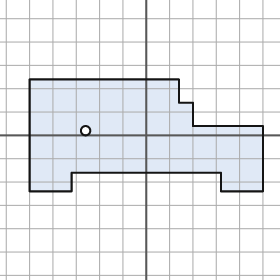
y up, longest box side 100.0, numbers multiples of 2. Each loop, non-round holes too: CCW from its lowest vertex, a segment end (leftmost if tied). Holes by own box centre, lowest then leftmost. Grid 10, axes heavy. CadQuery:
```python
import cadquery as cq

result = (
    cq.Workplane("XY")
    .moveTo(-50.0, -24.0)
    .lineTo(-32.0, -24.0)
    .lineTo(-32.0, -16.0)
    .lineTo(32.0, -16.0)
    .lineTo(32.0, -24.0)
    .lineTo(50.0, -24.0)
    .lineTo(50.0, 4.0)
    .lineTo(20.0, 4.0)
    .lineTo(20.0, 14.0)
    .lineTo(14.0, 14.0)
    .lineTo(14.0, 24.0)
    .lineTo(-50.0, 24.0)
    .close()
    .moveTo(-26.0, 2.0)
    .circle(2.0)
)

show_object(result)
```